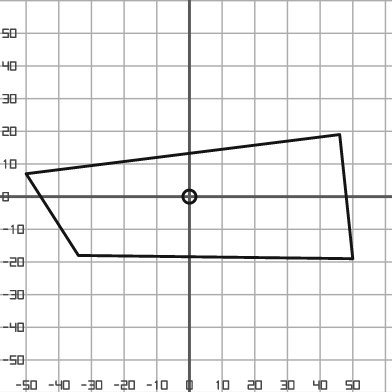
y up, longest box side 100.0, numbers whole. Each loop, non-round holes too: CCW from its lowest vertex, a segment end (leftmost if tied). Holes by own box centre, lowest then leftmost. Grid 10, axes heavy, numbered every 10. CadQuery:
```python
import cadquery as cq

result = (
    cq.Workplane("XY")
    .moveTo(50.0, -19.0)
    .lineTo(46.0, 19.0)
    .lineTo(-50.0, 7.0)
    .lineTo(-34.0, -18.0)
    .close()
    .moveTo(0.0, 0.0)
    .circle(2.0)
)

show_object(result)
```